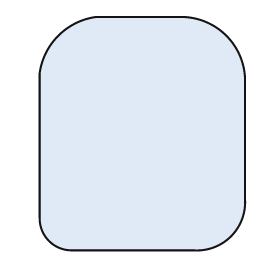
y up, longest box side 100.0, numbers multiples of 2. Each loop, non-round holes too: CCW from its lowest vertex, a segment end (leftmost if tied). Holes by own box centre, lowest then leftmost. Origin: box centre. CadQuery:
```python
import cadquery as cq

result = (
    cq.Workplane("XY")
    .moveTo(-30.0, -50.0)
    .lineTo(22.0, -50.0)
    .threePointArc((38.0, -44.0), (44.0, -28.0))
    .lineTo(44.0, 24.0)
    .threePointArc((36.0, 42.0), (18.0, 50.0))
    .lineTo(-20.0, 50.0)
    .threePointArc((-36.0, 42.0), (-44.0, 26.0))
    .lineTo(-44.0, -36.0)
    .threePointArc((-40.0, -46.0), (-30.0, -50.0))
    .close()
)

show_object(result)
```